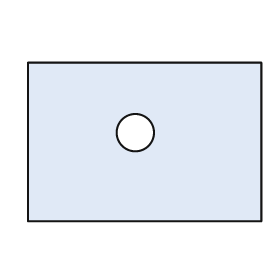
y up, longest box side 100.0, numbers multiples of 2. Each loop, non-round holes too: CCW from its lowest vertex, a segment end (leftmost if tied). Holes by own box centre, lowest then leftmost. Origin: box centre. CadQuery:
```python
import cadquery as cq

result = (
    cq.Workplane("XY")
    .moveTo(-50.0, -34.0)
    .lineTo(50.0, -34.0)
    .lineTo(50.0, 34.0)
    .lineTo(-50.0, 34.0)
    .close()
    .moveTo(-4.0, 4.0)
    .circle(8.0)
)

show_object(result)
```